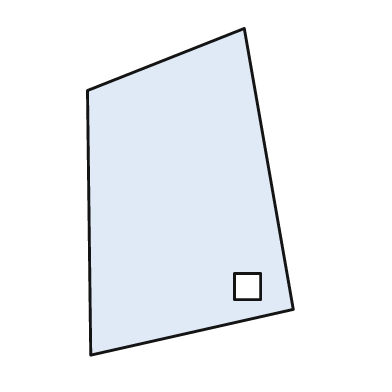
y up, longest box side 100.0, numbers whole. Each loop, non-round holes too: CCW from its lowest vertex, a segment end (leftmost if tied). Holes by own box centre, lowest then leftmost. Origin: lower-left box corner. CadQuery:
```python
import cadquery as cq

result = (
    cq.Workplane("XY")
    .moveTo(1.0, 0.0)
    .lineTo(63.0, 14.0)
    .lineTo(48.0, 100.0)
    .lineTo(0.0, 81.0)
    .close()
    .moveTo(45.0, 17.0)
    .lineTo(53.0, 17.0)
    .lineTo(53.0, 25.0)
    .lineTo(45.0, 25.0)
    .close()
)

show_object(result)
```